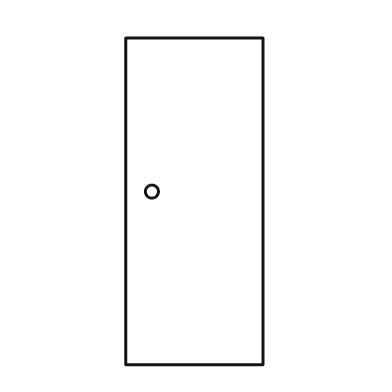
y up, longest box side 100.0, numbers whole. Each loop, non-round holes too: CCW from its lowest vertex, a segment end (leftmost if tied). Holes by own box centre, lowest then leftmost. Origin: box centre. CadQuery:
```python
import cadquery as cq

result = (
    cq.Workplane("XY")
    .moveTo(-21.0, -50.0)
    .lineTo(21.0, -50.0)
    .lineTo(21.0, 50.0)
    .lineTo(-21.0, 50.0)
    .close()
    .moveTo(-13.0, 3.0)
    .circle(2.0)
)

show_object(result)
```